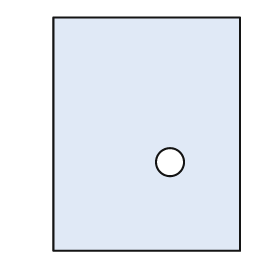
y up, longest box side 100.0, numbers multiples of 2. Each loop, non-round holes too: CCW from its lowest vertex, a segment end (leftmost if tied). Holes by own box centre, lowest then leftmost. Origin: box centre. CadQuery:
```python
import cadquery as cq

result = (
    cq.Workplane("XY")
    .moveTo(-40.0, -50.0)
    .lineTo(40.0, -50.0)
    .lineTo(40.0, 50.0)
    .lineTo(-40.0, 50.0)
    .close()
    .moveTo(10.0, -12.0)
    .circle(6.0)
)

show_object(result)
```